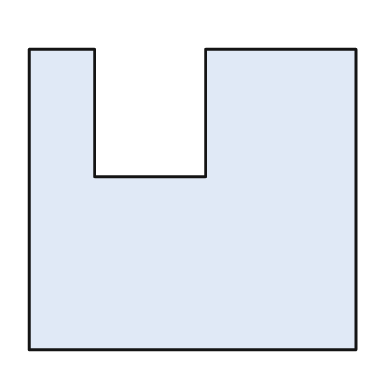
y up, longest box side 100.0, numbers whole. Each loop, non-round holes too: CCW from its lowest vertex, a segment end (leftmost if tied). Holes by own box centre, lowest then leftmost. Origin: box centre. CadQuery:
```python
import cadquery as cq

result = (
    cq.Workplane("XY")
    .moveTo(-50.0, -46.0)
    .lineTo(50.0, -46.0)
    .lineTo(50.0, 46.0)
    .lineTo(4.0, 46.0)
    .lineTo(4.0, 7.0)
    .lineTo(-30.0, 7.0)
    .lineTo(-30.0, 46.0)
    .lineTo(-50.0, 46.0)
    .close()
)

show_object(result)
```